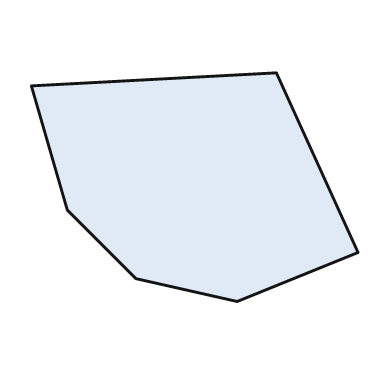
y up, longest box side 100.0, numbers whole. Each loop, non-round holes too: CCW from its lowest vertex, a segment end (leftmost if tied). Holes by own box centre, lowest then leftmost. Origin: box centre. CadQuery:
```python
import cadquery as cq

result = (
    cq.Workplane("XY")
    .moveTo(13.0, -35.0)
    .lineTo(50.0, -20.0)
    .lineTo(25.0, 35.0)
    .lineTo(-50.0, 31.0)
    .lineTo(-39.0, -7.0)
    .lineTo(-18.0, -28.0)
    .close()
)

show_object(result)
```